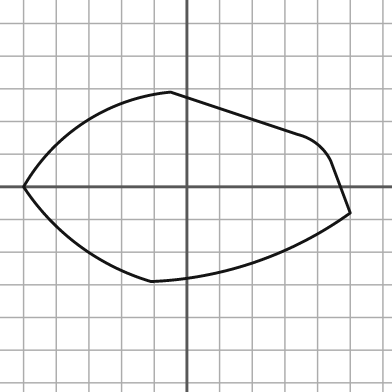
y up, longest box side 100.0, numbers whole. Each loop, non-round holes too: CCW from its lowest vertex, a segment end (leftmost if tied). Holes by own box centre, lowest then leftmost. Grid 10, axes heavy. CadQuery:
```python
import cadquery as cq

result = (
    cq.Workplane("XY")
    .moveTo(-11.0, -29.0)
    .threePointArc((21.0, -23.0), (50.0, -8.0))
    .lineTo(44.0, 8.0)
    .threePointArc((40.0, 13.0), (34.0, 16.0))
    .lineTo(-5.0, 29.0)
    .threePointArc((-31.0, 20.0), (-50.0, 0.0))
    .threePointArc((-33.0, -18.0), (-11.0, -29.0))
    .close()
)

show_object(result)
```